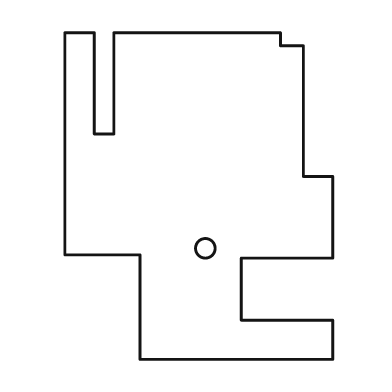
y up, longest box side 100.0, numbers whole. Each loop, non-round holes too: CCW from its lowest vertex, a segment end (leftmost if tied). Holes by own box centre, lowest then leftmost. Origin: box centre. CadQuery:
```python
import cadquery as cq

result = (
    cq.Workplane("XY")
    .moveTo(-18.0, -50.0)
    .lineTo(41.0, -50.0)
    .lineTo(41.0, -38.0)
    .lineTo(13.0, -38.0)
    .lineTo(13.0, -19.0)
    .lineTo(41.0, -19.0)
    .lineTo(41.0, 6.0)
    .lineTo(32.0, 6.0)
    .lineTo(32.0, 46.0)
    .lineTo(25.0, 46.0)
    .lineTo(25.0, 50.0)
    .lineTo(-26.0, 50.0)
    .lineTo(-26.0, 19.0)
    .lineTo(-32.0, 19.0)
    .lineTo(-32.0, 50.0)
    .lineTo(-41.0, 50.0)
    .lineTo(-41.0, -18.0)
    .lineTo(-18.0, -18.0)
    .close()
    .moveTo(2.0, -16.0)
    .circle(3.0)
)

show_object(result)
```